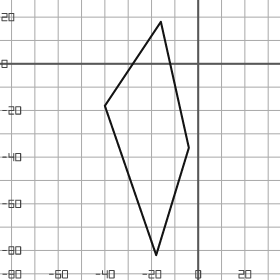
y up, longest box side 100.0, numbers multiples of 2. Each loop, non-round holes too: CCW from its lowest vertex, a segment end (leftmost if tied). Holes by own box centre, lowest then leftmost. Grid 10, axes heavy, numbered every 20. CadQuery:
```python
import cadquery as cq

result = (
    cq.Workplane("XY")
    .moveTo(-18.0, -82.0)
    .lineTo(-4.0, -36.0)
    .lineTo(-16.0, 18.0)
    .lineTo(-40.0, -18.0)
    .close()
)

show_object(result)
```